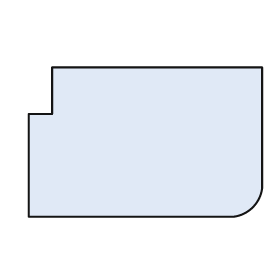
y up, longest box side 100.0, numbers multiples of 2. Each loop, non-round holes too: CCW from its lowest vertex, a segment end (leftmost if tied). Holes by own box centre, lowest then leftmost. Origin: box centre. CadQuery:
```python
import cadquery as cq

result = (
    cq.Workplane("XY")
    .moveTo(-50.0, -32.0)
    .lineTo(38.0, -32.0)
    .threePointArc((46.0, -28.0), (50.0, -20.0))
    .lineTo(50.0, 32.0)
    .lineTo(-40.0, 32.0)
    .lineTo(-40.0, 12.0)
    .lineTo(-50.0, 12.0)
    .close()
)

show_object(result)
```